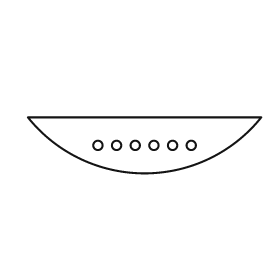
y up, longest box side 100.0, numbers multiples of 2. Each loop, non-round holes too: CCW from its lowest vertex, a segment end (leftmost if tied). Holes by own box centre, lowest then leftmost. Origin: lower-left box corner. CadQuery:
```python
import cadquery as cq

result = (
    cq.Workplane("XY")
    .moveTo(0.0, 24.0)
    .threePointArc((50.0, 0.0), (100.0, 24.0))
    .close()
    .moveTo(30.0, 12.0)
    .circle(2.0)
    .moveTo(38.0, 12.0)
    .circle(2.0)
    .moveTo(46.0, 12.0)
    .circle(2.0)
    .moveTo(54.0, 12.0)
    .circle(2.0)
    .moveTo(62.0, 12.0)
    .circle(2.0)
    .moveTo(70.0, 12.0)
    .circle(2.0)
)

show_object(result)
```